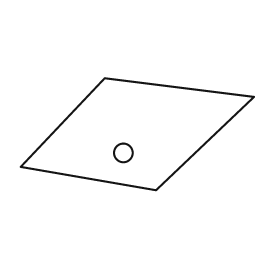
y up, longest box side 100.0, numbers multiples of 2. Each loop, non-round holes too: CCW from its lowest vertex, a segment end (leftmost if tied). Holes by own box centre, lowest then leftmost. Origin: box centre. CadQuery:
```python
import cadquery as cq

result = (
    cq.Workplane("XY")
    .moveTo(8.0, -24.0)
    .lineTo(50.0, 16.0)
    .lineTo(-14.0, 24.0)
    .lineTo(-50.0, -14.0)
    .close()
    .moveTo(-6.0, -8.0)
    .circle(4.0)
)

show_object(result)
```